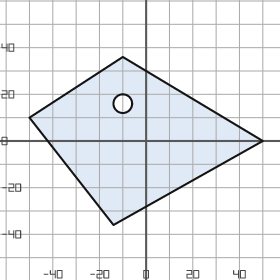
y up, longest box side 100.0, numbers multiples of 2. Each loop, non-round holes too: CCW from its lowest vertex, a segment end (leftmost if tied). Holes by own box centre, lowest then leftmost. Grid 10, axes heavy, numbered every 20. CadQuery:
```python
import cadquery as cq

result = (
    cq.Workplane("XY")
    .moveTo(-14.0, -36.0)
    .lineTo(50.0, 0.0)
    .lineTo(-10.0, 36.0)
    .lineTo(-50.0, 10.0)
    .close()
    .moveTo(-10.0, 16.0)
    .circle(4.0)
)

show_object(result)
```